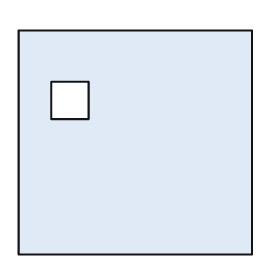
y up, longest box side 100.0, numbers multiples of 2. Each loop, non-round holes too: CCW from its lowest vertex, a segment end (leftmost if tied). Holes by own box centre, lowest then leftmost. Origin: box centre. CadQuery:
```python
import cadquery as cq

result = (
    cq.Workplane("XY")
    .moveTo(-50.0, -48.0)
    .lineTo(50.0, -48.0)
    .lineTo(50.0, 48.0)
    .lineTo(-50.0, 48.0)
    .close()
    .moveTo(-36.0, 10.0)
    .lineTo(-20.0, 10.0)
    .lineTo(-20.0, 26.0)
    .lineTo(-36.0, 26.0)
    .close()
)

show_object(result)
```